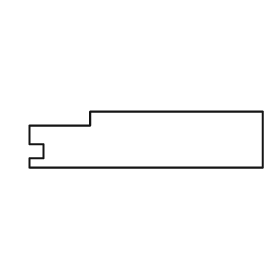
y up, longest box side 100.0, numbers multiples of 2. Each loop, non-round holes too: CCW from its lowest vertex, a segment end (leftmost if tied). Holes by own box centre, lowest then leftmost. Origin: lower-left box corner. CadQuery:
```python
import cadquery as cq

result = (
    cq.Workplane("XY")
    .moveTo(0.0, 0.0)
    .lineTo(100.0, 0.0)
    .lineTo(100.0, 24.0)
    .lineTo(26.0, 24.0)
    .lineTo(26.0, 18.0)
    .lineTo(0.0, 18.0)
    .lineTo(0.0, 10.0)
    .lineTo(6.0, 10.0)
    .lineTo(6.0, 4.0)
    .lineTo(0.0, 4.0)
    .close()
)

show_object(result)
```